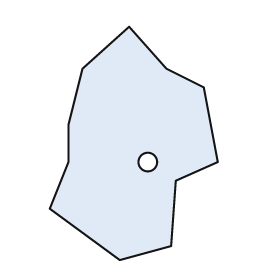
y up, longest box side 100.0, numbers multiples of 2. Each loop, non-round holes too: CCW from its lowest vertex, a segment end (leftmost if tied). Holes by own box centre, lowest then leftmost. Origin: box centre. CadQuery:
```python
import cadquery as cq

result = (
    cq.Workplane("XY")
    .moveTo(-6.0, -50.0)
    .lineTo(16.0, -44.0)
    .lineTo(18.0, -16.0)
    .lineTo(36.0, -8.0)
    .lineTo(30.0, 24.0)
    .lineTo(14.0, 32.0)
    .lineTo(-2.0, 50.0)
    .lineTo(-22.0, 32.0)
    .lineTo(-28.0, 8.0)
    .lineTo(-28.0, -8.0)
    .lineTo(-36.0, -28.0)
    .close()
    .moveTo(6.0, -8.0)
    .circle(4.0)
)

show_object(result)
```